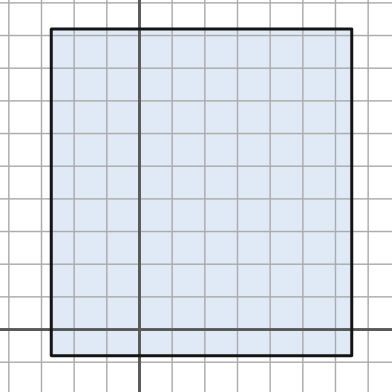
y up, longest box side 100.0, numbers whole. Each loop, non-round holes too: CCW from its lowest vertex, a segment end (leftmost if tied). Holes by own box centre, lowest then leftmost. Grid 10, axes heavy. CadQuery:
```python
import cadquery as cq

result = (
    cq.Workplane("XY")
    .moveTo(-27.0, -8.0)
    .lineTo(65.0, -8.0)
    .lineTo(65.0, 92.0)
    .lineTo(-27.0, 92.0)
    .close()
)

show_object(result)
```